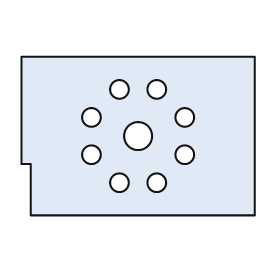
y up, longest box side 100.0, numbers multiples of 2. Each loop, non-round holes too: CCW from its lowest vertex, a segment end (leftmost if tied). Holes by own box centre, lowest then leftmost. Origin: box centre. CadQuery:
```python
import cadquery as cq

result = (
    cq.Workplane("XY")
    .moveTo(-46.0, -34.0)
    .lineTo(50.0, -34.0)
    .lineTo(50.0, 34.0)
    .lineTo(-50.0, 34.0)
    .lineTo(-50.0, -12.0)
    .lineTo(-46.0, -12.0)
    .close()
    .moveTo(-8.0, -20.0)
    .circle(4.0)
    .moveTo(8.0, -20.0)
    .circle(4.0)
    .moveTo(-20.0, -8.0)
    .circle(4.0)
    .moveTo(20.0, -8.0)
    .circle(4.0)
    .moveTo(0.0, 0.0)
    .circle(6.0)
    .moveTo(-20.0, 8.0)
    .circle(4.0)
    .moveTo(20.0, 8.0)
    .circle(4.0)
    .moveTo(-8.0, 20.0)
    .circle(4.0)
    .moveTo(8.0, 20.0)
    .circle(4.0)
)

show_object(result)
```